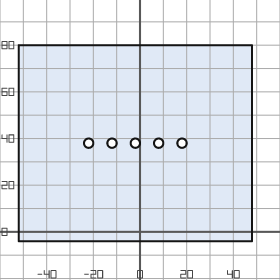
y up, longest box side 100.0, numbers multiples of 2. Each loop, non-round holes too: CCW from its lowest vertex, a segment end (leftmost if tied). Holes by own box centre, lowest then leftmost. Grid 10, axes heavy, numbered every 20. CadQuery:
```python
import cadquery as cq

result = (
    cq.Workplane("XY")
    .moveTo(-52.0, -4.0)
    .lineTo(48.0, -4.0)
    .lineTo(48.0, 80.0)
    .lineTo(-52.0, 80.0)
    .close()
    .moveTo(-22.0, 38.0)
    .circle(2.0)
    .moveTo(-12.0, 38.0)
    .circle(2.0)
    .moveTo(-2.0, 38.0)
    .circle(2.0)
    .moveTo(8.0, 38.0)
    .circle(2.0)
    .moveTo(18.0, 38.0)
    .circle(2.0)
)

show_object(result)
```